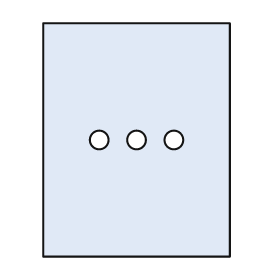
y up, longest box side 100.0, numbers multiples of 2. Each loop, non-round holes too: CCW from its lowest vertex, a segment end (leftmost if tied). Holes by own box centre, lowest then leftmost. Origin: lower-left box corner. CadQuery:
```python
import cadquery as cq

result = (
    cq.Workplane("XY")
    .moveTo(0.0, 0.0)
    .lineTo(80.0, 0.0)
    .lineTo(80.0, 100.0)
    .lineTo(0.0, 100.0)
    .close()
    .moveTo(24.0, 50.0)
    .circle(4.0)
    .moveTo(40.0, 50.0)
    .circle(4.0)
    .moveTo(56.0, 50.0)
    .circle(4.0)
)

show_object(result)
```